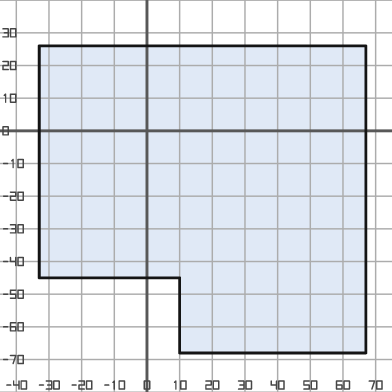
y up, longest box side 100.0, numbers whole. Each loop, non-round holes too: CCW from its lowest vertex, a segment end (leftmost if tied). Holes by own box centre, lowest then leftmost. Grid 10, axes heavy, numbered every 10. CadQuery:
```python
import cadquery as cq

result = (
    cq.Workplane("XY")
    .moveTo(10.0, -68.0)
    .lineTo(67.0, -68.0)
    .lineTo(67.0, 26.0)
    .lineTo(-33.0, 26.0)
    .lineTo(-33.0, -45.0)
    .lineTo(10.0, -45.0)
    .close()
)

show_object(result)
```